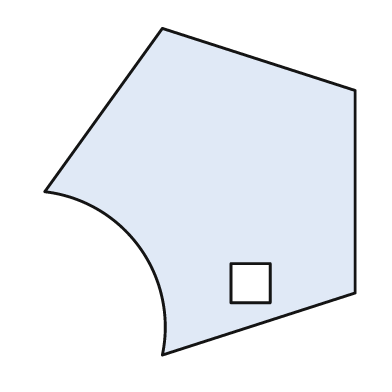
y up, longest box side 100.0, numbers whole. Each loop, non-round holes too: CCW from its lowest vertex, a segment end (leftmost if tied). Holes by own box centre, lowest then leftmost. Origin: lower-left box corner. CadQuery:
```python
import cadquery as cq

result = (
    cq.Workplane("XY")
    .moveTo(36.0, 0.0)
    .lineTo(95.0, 19.0)
    .lineTo(95.0, 81.0)
    .lineTo(36.0, 100.0)
    .lineTo(0.0, 50.0)
    .threePointArc((29.0, 33.0), (36.0, 0.0))
    .close()
    .moveTo(57.0, 16.0)
    .lineTo(69.0, 16.0)
    .lineTo(69.0, 28.0)
    .lineTo(57.0, 28.0)
    .close()
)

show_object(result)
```